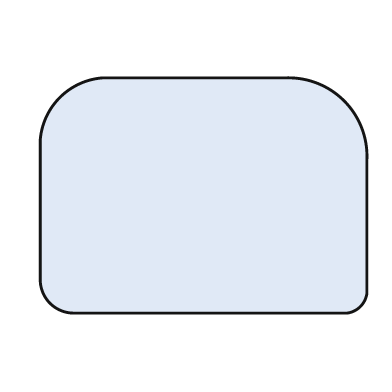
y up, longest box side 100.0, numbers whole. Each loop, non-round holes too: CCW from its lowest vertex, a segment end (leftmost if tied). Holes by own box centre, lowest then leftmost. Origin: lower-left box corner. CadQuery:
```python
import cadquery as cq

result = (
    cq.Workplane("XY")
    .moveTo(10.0, 0.0)
    .lineTo(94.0, 0.0)
    .threePointArc((98.0, 2.0), (100.0, 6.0))
    .lineTo(100.0, 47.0)
    .threePointArc((93.0, 65.0), (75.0, 72.0))
    .lineTo(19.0, 72.0)
    .threePointArc((6.0, 66.0), (0.0, 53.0))
    .lineTo(0.0, 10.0)
    .threePointArc((3.0, 3.0), (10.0, 0.0))
    .close()
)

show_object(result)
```